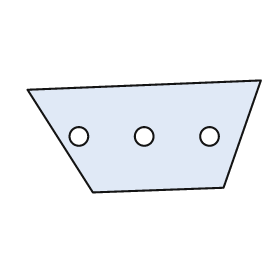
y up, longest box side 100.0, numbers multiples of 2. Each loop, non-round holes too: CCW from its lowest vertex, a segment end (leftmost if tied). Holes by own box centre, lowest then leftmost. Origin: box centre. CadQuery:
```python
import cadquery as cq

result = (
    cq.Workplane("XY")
    .moveTo(-22.0, -24.0)
    .lineTo(34.0, -22.0)
    .lineTo(50.0, 24.0)
    .lineTo(-50.0, 20.0)
    .close()
    .moveTo(-28.0, 0.0)
    .circle(4.0)
    .moveTo(0.0, 0.0)
    .circle(4.0)
    .moveTo(28.0, 0.0)
    .circle(4.0)
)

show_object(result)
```